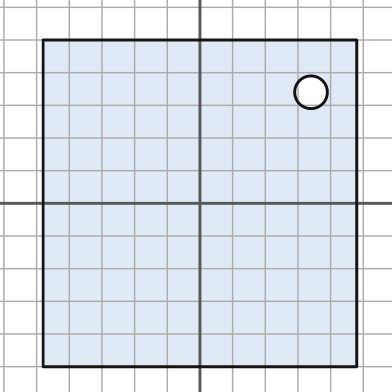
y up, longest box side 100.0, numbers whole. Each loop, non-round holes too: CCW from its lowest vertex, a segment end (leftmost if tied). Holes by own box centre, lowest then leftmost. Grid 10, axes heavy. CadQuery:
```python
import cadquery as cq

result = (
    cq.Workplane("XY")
    .moveTo(-48.0, -50.0)
    .lineTo(48.0, -50.0)
    .lineTo(48.0, 50.0)
    .lineTo(-48.0, 50.0)
    .close()
    .moveTo(34.0, 34.0)
    .circle(5.0)
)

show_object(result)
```